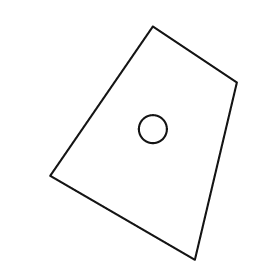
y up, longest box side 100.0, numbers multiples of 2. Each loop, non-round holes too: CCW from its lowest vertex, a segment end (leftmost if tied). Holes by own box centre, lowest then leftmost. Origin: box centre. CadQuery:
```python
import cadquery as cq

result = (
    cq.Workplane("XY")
    .moveTo(22.0, -50.0)
    .lineTo(40.0, 26.0)
    .lineTo(4.0, 50.0)
    .lineTo(-40.0, -14.0)
    .close()
    .moveTo(4.0, 6.0)
    .circle(6.0)
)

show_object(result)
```